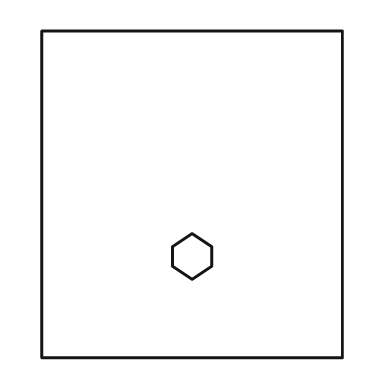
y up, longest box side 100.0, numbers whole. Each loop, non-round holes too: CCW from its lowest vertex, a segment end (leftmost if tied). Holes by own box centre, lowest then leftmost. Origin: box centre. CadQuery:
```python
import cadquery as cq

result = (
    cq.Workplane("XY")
    .moveTo(-46.0, -50.0)
    .lineTo(46.0, -50.0)
    .lineTo(46.0, 50.0)
    .lineTo(-46.0, 50.0)
    .close()
    .moveTo(0.0, -26.0)
    .lineTo(6.0, -22.0)
    .lineTo(6.0, -16.0)
    .lineTo(0.0, -12.0)
    .lineTo(-6.0, -16.0)
    .lineTo(-6.0, -22.0)
    .close()
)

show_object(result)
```